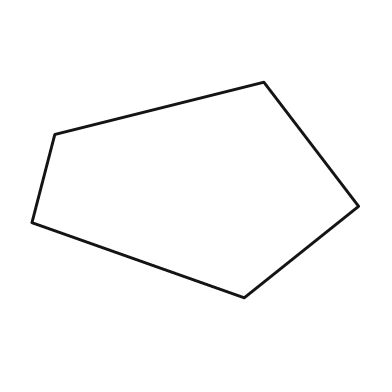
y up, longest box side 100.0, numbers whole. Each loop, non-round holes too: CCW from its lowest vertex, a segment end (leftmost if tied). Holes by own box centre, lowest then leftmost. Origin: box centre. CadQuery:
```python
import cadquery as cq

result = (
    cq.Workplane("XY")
    .moveTo(15.0, -33.0)
    .lineTo(50.0, -5.0)
    .lineTo(21.0, 33.0)
    .lineTo(-43.0, 17.0)
    .lineTo(-50.0, -10.0)
    .close()
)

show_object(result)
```